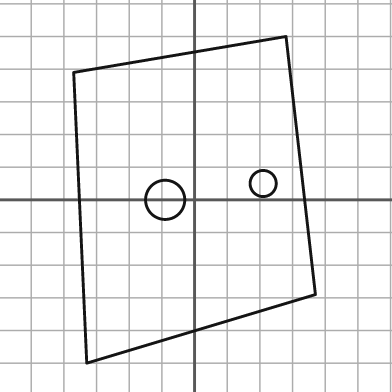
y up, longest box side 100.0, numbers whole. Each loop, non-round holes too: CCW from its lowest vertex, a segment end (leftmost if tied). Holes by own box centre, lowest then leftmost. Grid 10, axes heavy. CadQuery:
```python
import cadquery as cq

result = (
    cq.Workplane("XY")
    .moveTo(-33.0, -50.0)
    .lineTo(37.0, -29.0)
    .lineTo(28.0, 50.0)
    .lineTo(-37.0, 39.0)
    .close()
    .moveTo(-9.0, 0.0)
    .circle(6.0)
    .moveTo(21.0, 5.0)
    .circle(4.0)
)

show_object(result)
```